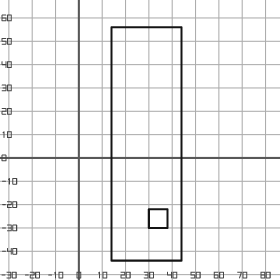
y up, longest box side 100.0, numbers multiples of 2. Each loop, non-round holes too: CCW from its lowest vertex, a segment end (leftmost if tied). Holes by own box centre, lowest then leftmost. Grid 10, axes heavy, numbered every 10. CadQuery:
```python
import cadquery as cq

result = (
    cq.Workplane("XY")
    .moveTo(14.0, -44.0)
    .lineTo(44.0, -44.0)
    .lineTo(44.0, 56.0)
    .lineTo(14.0, 56.0)
    .close()
    .moveTo(30.0, -30.0)
    .lineTo(38.0, -30.0)
    .lineTo(38.0, -22.0)
    .lineTo(30.0, -22.0)
    .close()
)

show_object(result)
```